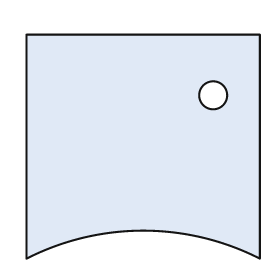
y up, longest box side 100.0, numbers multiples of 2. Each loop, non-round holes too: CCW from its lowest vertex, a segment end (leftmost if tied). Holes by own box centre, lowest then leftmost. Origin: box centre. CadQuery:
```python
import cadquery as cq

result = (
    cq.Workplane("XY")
    .moveTo(-50.0, -48.0)
    .threePointArc((0.0, -36.0), (50.0, -48.0))
    .lineTo(50.0, 48.0)
    .lineTo(-50.0, 48.0)
    .close()
    .moveTo(30.0, 22.0)
    .circle(6.0)
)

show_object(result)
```